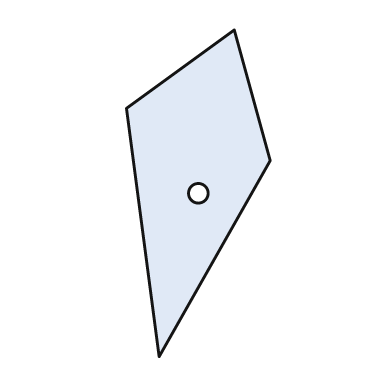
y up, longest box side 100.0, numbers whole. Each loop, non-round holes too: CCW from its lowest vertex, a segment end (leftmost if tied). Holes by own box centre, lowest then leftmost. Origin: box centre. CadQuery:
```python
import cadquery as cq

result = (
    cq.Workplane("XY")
    .moveTo(-12.0, -50.0)
    .lineTo(22.0, 10.0)
    .lineTo(11.0, 50.0)
    .lineTo(-22.0, 26.0)
    .close()
    .moveTo(0.0, 0.0)
    .circle(3.0)
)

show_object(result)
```